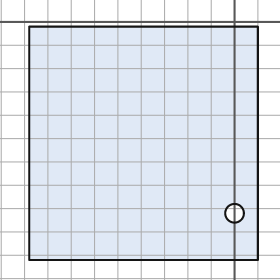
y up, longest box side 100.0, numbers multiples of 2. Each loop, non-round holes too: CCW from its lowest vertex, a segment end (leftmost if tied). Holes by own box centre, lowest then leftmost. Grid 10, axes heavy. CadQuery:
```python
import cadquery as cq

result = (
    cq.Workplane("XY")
    .moveTo(-88.0, -102.0)
    .lineTo(10.0, -102.0)
    .lineTo(10.0, -2.0)
    .lineTo(-88.0, -2.0)
    .close()
    .moveTo(0.0, -82.0)
    .circle(4.0)
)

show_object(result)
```